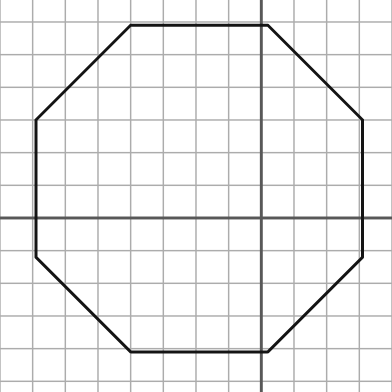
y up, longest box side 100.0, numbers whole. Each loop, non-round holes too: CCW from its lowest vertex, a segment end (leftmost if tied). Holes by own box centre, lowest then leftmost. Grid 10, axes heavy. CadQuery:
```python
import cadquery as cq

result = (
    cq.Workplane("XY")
    .moveTo(-40.0, -41.0)
    .lineTo(2.0, -41.0)
    .lineTo(31.0, -12.0)
    .lineTo(31.0, 30.0)
    .lineTo(2.0, 59.0)
    .lineTo(-40.0, 59.0)
    .lineTo(-69.0, 30.0)
    .lineTo(-69.0, -12.0)
    .close()
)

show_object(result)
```